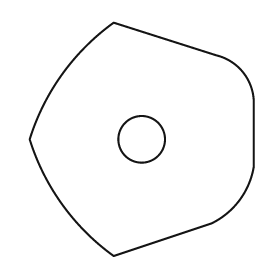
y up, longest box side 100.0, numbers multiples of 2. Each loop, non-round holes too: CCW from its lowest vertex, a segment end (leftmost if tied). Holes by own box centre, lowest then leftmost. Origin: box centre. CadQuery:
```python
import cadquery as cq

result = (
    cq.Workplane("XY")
    .moveTo(-12.0, -50.0)
    .lineTo(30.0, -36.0)
    .threePointArc((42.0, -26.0), (48.0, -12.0))
    .lineTo(48.0, 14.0)
    .threePointArc((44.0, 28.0), (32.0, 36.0))
    .lineTo(-12.0, 50.0)
    .threePointArc((-34.0, 28.0), (-48.0, 0.0))
    .threePointArc((-34.0, -28.0), (-12.0, -50.0))
    .close()
    .moveTo(0.0, 0.0)
    .circle(10.0)
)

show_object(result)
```